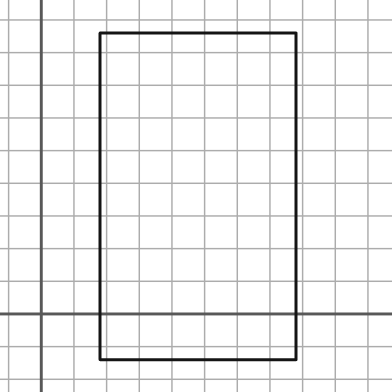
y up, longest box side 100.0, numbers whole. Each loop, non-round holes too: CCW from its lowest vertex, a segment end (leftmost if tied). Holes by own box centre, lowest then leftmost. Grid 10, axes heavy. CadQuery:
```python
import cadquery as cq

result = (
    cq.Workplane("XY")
    .moveTo(18.0, -14.0)
    .lineTo(78.0, -14.0)
    .lineTo(78.0, 86.0)
    .lineTo(18.0, 86.0)
    .close()
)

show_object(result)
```